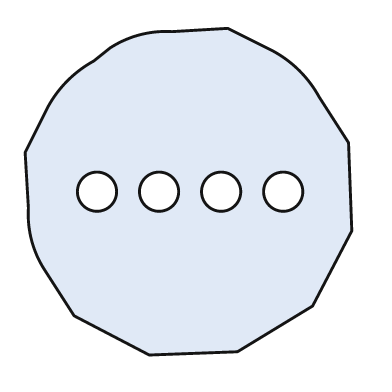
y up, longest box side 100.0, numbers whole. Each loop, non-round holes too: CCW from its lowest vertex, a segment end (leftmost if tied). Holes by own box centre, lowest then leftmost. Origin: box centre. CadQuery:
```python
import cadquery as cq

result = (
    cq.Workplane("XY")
    .moveTo(-12.0, -50.0)
    .lineTo(15.0, -49.0)
    .lineTo(38.0, -35.0)
    .lineTo(50.0, -12.0)
    .lineTo(49.0, 15.0)
    .lineTo(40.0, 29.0)
    .threePointArc((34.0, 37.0), (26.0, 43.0))
    .lineTo(12.0, 50.0)
    .lineTo(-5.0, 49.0)
    .threePointArc((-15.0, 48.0), (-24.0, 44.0))
    .lineTo(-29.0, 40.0)
    .threePointArc((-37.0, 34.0), (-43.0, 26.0))
    .lineTo(-50.0, 12.0)
    .lineTo(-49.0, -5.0)
    .threePointArc((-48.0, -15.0), (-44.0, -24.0))
    .lineTo(-35.0, -38.0)
    .close()
    .moveTo(-28.0, 0.0)
    .circle(6.0)
    .moveTo(-9.0, 0.0)
    .circle(6.0)
    .moveTo(10.0, 0.0)
    .circle(6.0)
    .moveTo(29.0, 0.0)
    .circle(6.0)
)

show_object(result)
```